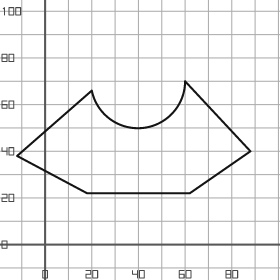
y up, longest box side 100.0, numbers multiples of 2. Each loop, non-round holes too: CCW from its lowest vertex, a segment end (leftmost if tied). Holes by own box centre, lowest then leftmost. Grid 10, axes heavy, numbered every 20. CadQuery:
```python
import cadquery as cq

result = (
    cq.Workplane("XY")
    .moveTo(18.0, 22.0)
    .lineTo(62.0, 22.0)
    .lineTo(88.0, 40.0)
    .lineTo(60.0, 70.0)
    .threePointArc((42.0, 50.0), (20.0, 66.0))
    .lineTo(-12.0, 38.0)
    .close()
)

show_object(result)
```